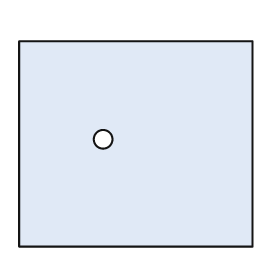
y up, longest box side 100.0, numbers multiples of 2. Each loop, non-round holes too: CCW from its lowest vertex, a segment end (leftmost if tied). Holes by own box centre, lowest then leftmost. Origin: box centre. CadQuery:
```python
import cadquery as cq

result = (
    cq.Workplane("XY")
    .moveTo(-50.0, -44.0)
    .lineTo(50.0, -44.0)
    .lineTo(50.0, 44.0)
    .lineTo(-50.0, 44.0)
    .close()
    .moveTo(-14.0, 2.0)
    .circle(4.0)
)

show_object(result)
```